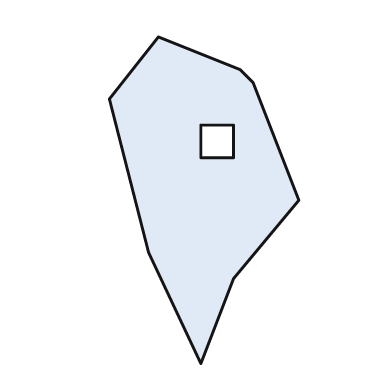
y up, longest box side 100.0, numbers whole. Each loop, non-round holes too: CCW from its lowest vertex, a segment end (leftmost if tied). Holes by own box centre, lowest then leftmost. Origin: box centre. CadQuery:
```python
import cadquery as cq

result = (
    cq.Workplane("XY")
    .moveTo(-1.0, -50.0)
    .lineTo(9.0, -24.0)
    .lineTo(29.0, 0.0)
    .lineTo(15.0, 36.0)
    .lineTo(11.0, 40.0)
    .lineTo(-14.0, 50.0)
    .lineTo(-29.0, 31.0)
    .lineTo(-17.0, -16.0)
    .close()
    .moveTo(-1.0, 13.0)
    .lineTo(9.0, 13.0)
    .lineTo(9.0, 23.0)
    .lineTo(-1.0, 23.0)
    .close()
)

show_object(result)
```